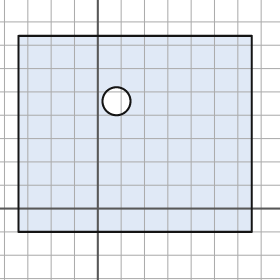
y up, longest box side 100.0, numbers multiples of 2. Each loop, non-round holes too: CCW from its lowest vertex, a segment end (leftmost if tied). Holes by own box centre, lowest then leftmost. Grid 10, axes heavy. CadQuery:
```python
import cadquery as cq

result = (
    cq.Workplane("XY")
    .moveTo(-34.0, -10.0)
    .lineTo(66.0, -10.0)
    .lineTo(66.0, 74.0)
    .lineTo(-34.0, 74.0)
    .close()
    .moveTo(8.0, 46.0)
    .circle(6.0)
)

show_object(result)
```